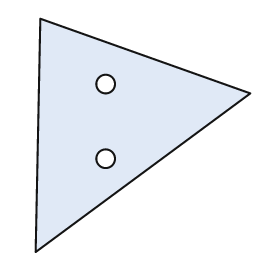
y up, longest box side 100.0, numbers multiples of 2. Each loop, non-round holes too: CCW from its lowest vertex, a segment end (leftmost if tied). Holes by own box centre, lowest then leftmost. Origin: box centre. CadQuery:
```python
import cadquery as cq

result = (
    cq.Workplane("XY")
    .moveTo(-46.0, -50.0)
    .lineTo(46.0, 18.0)
    .lineTo(-44.0, 50.0)
    .close()
    .moveTo(-16.0, -10.0)
    .circle(4.0)
    .moveTo(-16.0, 22.0)
    .circle(4.0)
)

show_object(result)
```